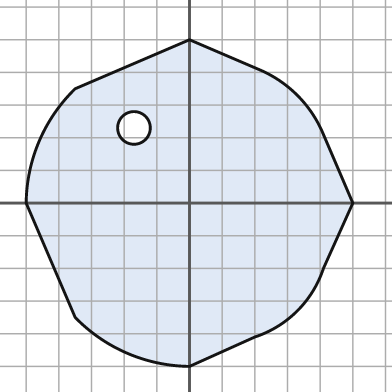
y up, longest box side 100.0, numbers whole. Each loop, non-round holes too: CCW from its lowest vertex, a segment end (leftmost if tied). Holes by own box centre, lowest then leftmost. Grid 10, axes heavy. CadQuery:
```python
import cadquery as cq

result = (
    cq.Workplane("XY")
    .moveTo(0.0, -50.0)
    .lineTo(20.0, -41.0)
    .threePointArc((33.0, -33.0), (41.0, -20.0))
    .lineTo(50.0, 0.0)
    .lineTo(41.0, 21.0)
    .threePointArc((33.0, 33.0), (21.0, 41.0))
    .lineTo(0.0, 50.0)
    .lineTo(-35.0, 35.0)
    .threePointArc((-46.0, 19.0), (-50.0, 0.0))
    .lineTo(-35.0, -35.0)
    .threePointArc((-19.0, -46.0), (0.0, -50.0))
    .close()
    .moveTo(-17.0, 23.0)
    .circle(5.0)
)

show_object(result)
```